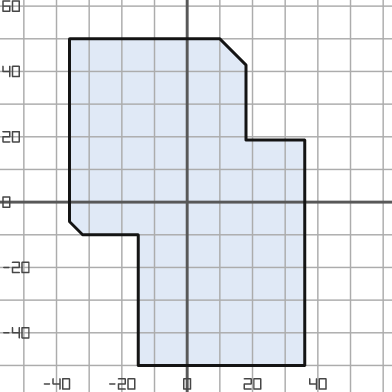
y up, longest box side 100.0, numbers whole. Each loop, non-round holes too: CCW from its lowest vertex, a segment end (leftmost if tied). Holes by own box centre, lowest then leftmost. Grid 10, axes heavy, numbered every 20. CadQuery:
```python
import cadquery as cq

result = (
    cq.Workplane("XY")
    .moveTo(-15.0, -50.0)
    .lineTo(36.0, -50.0)
    .lineTo(36.0, 19.0)
    .lineTo(18.0, 19.0)
    .lineTo(18.0, 42.0)
    .lineTo(10.0, 50.0)
    .lineTo(-36.0, 50.0)
    .lineTo(-36.0, -6.0)
    .lineTo(-32.0, -10.0)
    .lineTo(-15.0, -10.0)
    .close()
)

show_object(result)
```